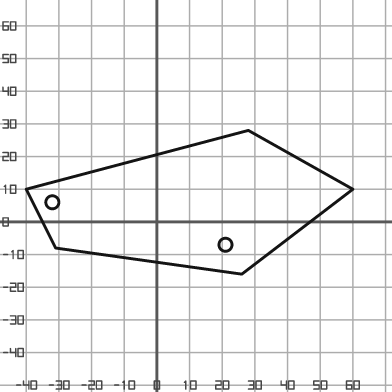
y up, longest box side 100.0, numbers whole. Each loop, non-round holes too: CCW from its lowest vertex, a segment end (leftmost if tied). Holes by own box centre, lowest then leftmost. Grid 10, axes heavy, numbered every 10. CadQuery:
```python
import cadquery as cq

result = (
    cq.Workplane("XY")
    .moveTo(26.0, -16.0)
    .lineTo(60.0, 10.0)
    .lineTo(28.0, 28.0)
    .lineTo(-40.0, 10.0)
    .lineTo(-31.0, -8.0)
    .close()
    .moveTo(21.0, -7.0)
    .circle(2.0)
    .moveTo(-32.0, 6.0)
    .circle(2.0)
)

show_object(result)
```